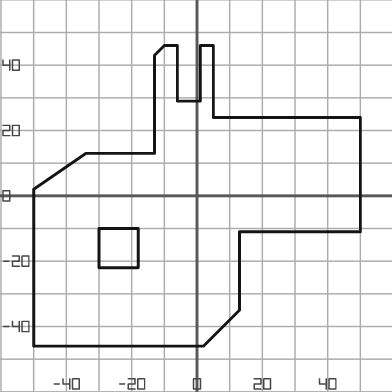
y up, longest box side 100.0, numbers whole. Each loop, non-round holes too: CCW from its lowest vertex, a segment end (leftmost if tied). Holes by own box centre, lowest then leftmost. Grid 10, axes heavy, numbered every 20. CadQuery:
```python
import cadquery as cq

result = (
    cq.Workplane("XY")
    .moveTo(-50.0, -46.0)
    .lineTo(2.0, -46.0)
    .lineTo(13.0, -35.0)
    .lineTo(13.0, -11.0)
    .lineTo(50.0, -11.0)
    .lineTo(50.0, 24.0)
    .lineTo(5.0, 24.0)
    .lineTo(5.0, 46.0)
    .lineTo(1.0, 46.0)
    .lineTo(1.0, 29.0)
    .lineTo(-6.0, 29.0)
    .lineTo(-6.0, 46.0)
    .lineTo(-10.0, 46.0)
    .lineTo(-13.0, 43.0)
    .lineTo(-13.0, 13.0)
    .lineTo(-34.0, 13.0)
    .lineTo(-50.0, 2.0)
    .close()
    .moveTo(-30.0, -22.0)
    .lineTo(-18.0, -22.0)
    .lineTo(-18.0, -10.0)
    .lineTo(-30.0, -10.0)
    .close()
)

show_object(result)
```